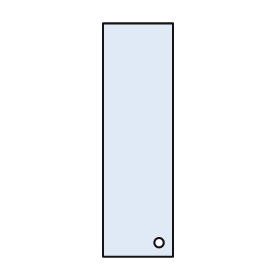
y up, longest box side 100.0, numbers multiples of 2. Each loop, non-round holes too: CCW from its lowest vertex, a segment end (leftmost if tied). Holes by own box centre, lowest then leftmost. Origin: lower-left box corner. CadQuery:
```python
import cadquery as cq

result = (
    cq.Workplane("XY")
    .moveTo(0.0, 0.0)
    .lineTo(30.0, 0.0)
    .lineTo(30.0, 100.0)
    .lineTo(0.0, 100.0)
    .close()
    .moveTo(24.0, 6.0)
    .circle(2.0)
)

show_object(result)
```